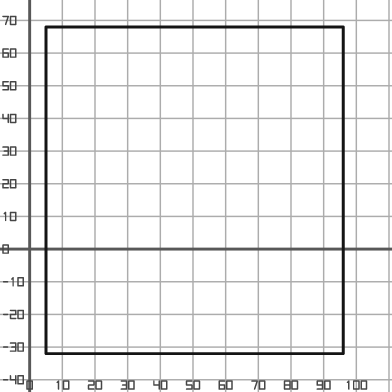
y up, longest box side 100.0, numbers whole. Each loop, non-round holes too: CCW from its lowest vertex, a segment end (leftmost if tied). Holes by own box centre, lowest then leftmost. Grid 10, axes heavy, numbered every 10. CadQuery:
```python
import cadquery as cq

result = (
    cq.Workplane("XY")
    .moveTo(5.0, -32.0)
    .lineTo(96.0, -32.0)
    .lineTo(96.0, 68.0)
    .lineTo(5.0, 68.0)
    .close()
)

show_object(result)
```